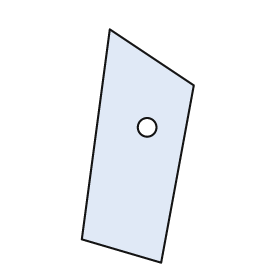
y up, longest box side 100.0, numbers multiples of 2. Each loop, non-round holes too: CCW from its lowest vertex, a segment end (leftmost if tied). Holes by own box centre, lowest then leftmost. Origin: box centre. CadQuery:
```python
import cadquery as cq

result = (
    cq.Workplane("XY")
    .moveTo(10.0, -50.0)
    .lineTo(24.0, 26.0)
    .lineTo(-12.0, 50.0)
    .lineTo(-24.0, -40.0)
    .close()
    .moveTo(4.0, 8.0)
    .circle(4.0)
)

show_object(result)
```